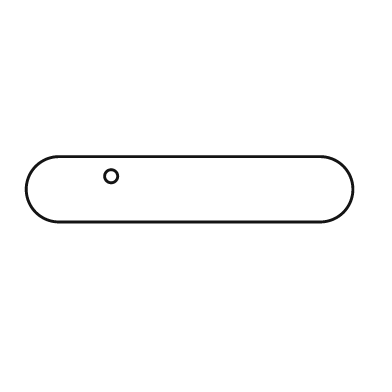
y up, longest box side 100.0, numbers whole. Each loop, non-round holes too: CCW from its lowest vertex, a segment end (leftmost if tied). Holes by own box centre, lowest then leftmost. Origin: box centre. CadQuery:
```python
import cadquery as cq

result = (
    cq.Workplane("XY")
    .moveTo(-40.0, -10.0)
    .lineTo(40.0, -10.0)
    .threePointArc((50.0, 0.0), (40.0, 10.0))
    .lineTo(-40.0, 10.0)
    .threePointArc((-50.0, 0.0), (-40.0, -10.0))
    .close()
    .moveTo(-24.0, 4.0)
    .circle(2.0)
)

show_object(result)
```